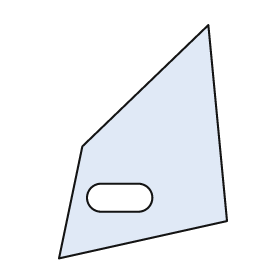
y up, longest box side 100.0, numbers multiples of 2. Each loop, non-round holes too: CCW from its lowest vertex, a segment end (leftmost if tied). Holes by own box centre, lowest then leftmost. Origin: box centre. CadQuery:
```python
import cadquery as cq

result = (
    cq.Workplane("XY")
    .moveTo(-36.0, -50.0)
    .lineTo(36.0, -34.0)
    .lineTo(28.0, 50.0)
    .lineTo(-26.0, -2.0)
    .close()
    .moveTo(-18.0, -30.0)
    .lineTo(-2.0, -30.0)
    .threePointArc((4.0, -24.0), (-2.0, -18.0))
    .lineTo(-18.0, -18.0)
    .threePointArc((-24.0, -24.0), (-18.0, -30.0))
    .close()
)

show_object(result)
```